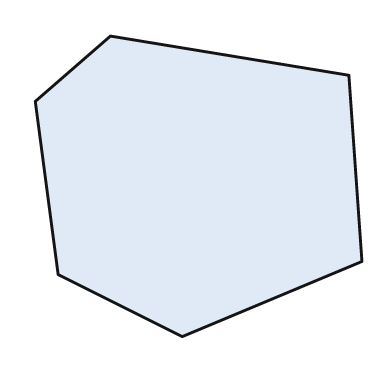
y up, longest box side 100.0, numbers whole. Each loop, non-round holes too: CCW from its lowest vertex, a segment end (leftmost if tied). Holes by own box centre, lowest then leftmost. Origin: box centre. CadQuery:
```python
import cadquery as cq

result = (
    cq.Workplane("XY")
    .moveTo(-5.0, -46.0)
    .lineTo(50.0, -23.0)
    .lineTo(46.0, 34.0)
    .lineTo(-27.0, 46.0)
    .lineTo(-50.0, 26.0)
    .lineTo(-43.0, -27.0)
    .close()
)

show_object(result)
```